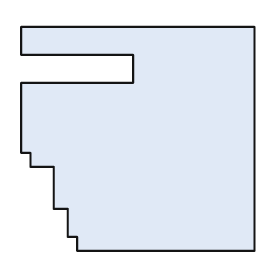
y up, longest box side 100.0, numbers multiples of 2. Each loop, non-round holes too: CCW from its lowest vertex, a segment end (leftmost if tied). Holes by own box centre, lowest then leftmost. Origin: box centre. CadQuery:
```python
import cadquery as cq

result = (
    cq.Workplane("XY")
    .moveTo(-26.0, -48.0)
    .lineTo(50.0, -48.0)
    .lineTo(50.0, 48.0)
    .lineTo(-50.0, 48.0)
    .lineTo(-50.0, 36.0)
    .lineTo(-2.0, 36.0)
    .lineTo(-2.0, 24.0)
    .lineTo(-50.0, 24.0)
    .lineTo(-50.0, -6.0)
    .lineTo(-46.0, -6.0)
    .lineTo(-46.0, -12.0)
    .lineTo(-36.0, -12.0)
    .lineTo(-36.0, -30.0)
    .lineTo(-30.0, -30.0)
    .lineTo(-30.0, -42.0)
    .lineTo(-26.0, -42.0)
    .close()
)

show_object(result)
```